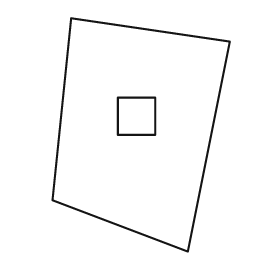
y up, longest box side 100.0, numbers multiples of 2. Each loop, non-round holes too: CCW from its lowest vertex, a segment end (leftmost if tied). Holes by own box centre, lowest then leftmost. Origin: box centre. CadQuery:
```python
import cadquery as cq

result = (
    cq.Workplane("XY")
    .moveTo(20.0, -50.0)
    .lineTo(38.0, 40.0)
    .lineTo(-30.0, 50.0)
    .lineTo(-38.0, -28.0)
    .close()
    .moveTo(-10.0, 0.0)
    .lineTo(6.0, 0.0)
    .lineTo(6.0, 16.0)
    .lineTo(-10.0, 16.0)
    .close()
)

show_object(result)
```